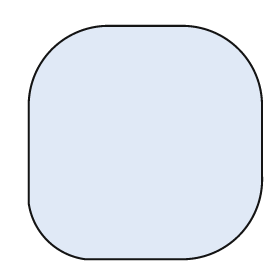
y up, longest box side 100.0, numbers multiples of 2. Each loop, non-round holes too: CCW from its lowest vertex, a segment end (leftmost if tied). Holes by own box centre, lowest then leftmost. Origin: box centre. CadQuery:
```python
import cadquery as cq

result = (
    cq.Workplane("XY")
    .moveTo(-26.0, -50.0)
    .lineTo(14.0, -50.0)
    .threePointArc((40.0, -40.0), (50.0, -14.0))
    .lineTo(50.0, 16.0)
    .threePointArc((40.0, 40.0), (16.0, 50.0))
    .lineTo(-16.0, 50.0)
    .threePointArc((-40.0, 40.0), (-50.0, 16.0))
    .lineTo(-50.0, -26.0)
    .threePointArc((-42.0, -42.0), (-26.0, -50.0))
    .close()
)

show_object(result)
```